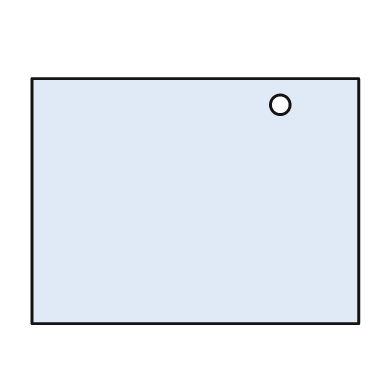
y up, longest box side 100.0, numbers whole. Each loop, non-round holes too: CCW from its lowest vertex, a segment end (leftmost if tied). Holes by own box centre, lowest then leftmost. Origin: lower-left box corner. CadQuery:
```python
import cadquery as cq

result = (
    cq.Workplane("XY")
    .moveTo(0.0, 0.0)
    .lineTo(100.0, 0.0)
    .lineTo(100.0, 75.0)
    .lineTo(0.0, 75.0)
    .close()
    .moveTo(76.0, 67.0)
    .circle(3.0)
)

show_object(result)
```